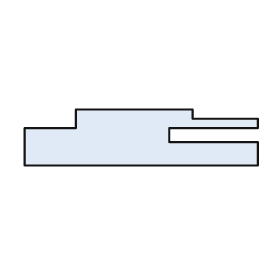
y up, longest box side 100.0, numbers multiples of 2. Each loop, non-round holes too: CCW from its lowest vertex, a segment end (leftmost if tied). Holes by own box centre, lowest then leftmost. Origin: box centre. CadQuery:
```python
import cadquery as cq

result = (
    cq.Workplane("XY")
    .moveTo(-50.0, -12.0)
    .lineTo(50.0, -12.0)
    .lineTo(50.0, -2.0)
    .lineTo(12.0, -2.0)
    .lineTo(12.0, 4.0)
    .lineTo(50.0, 4.0)
    .lineTo(50.0, 8.0)
    .lineTo(22.0, 8.0)
    .lineTo(22.0, 12.0)
    .lineTo(-28.0, 12.0)
    .lineTo(-28.0, 4.0)
    .lineTo(-50.0, 4.0)
    .close()
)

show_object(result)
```